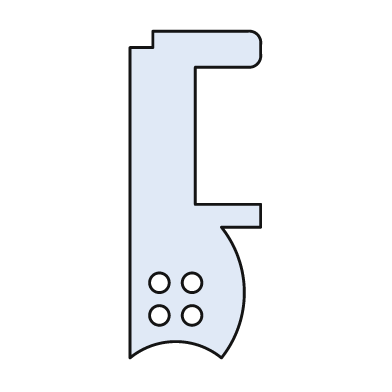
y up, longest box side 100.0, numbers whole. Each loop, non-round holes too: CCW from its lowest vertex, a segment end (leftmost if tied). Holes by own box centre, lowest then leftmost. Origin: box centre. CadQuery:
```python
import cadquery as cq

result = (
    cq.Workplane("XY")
    .moveTo(-20.0, -50.0)
    .threePointArc((-6.0, -45.0), (8.0, -50.0))
    .threePointArc((15.0, -30.0), (8.0, -10.0))
    .lineTo(20.0, -10.0)
    .lineTo(20.0, -3.0)
    .lineTo(0.0, -3.0)
    .lineTo(0.0, 39.0)
    .lineTo(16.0, 39.0)
    .threePointArc((19.0, 40.0), (20.0, 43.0))
    .lineTo(20.0, 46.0)
    .threePointArc((19.0, 49.0), (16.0, 50.0))
    .lineTo(-13.0, 50.0)
    .lineTo(-13.0, 45.0)
    .lineTo(-20.0, 45.0)
    .close()
    .moveTo(-11.0, -37.0)
    .circle(3.0)
    .moveTo(-1.0, -37.0)
    .circle(3.0)
    .moveTo(-11.0, -27.0)
    .circle(3.0)
    .moveTo(-1.0, -27.0)
    .circle(3.0)
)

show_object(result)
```